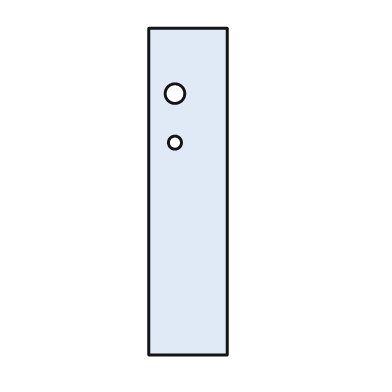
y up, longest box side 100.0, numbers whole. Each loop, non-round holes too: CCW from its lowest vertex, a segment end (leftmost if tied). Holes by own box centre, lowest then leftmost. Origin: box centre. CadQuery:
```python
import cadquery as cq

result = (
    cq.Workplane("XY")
    .moveTo(-12.0, -50.0)
    .lineTo(12.0, -50.0)
    .lineTo(12.0, 50.0)
    .lineTo(-12.0, 50.0)
    .close()
    .moveTo(-4.0, 15.0)
    .circle(2.0)
    .moveTo(-4.0, 30.0)
    .circle(3.0)
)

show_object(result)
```